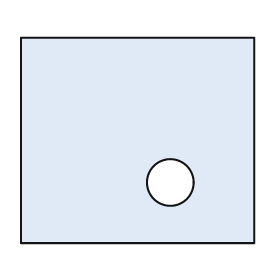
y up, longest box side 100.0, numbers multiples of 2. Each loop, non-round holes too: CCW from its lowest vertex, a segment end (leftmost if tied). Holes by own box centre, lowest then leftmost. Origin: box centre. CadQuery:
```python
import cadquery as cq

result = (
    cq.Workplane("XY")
    .moveTo(-50.0, -44.0)
    .lineTo(50.0, -44.0)
    .lineTo(50.0, 44.0)
    .lineTo(-50.0, 44.0)
    .close()
    .moveTo(14.0, -18.0)
    .circle(10.0)
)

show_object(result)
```